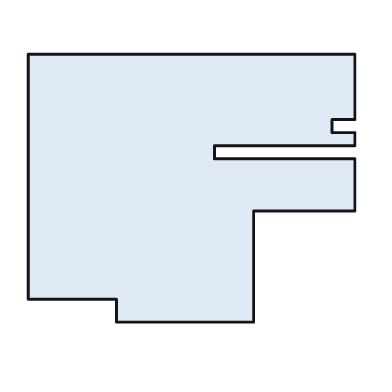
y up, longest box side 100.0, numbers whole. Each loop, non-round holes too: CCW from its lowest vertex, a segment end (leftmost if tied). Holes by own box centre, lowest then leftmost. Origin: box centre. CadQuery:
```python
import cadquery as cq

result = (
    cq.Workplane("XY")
    .moveTo(-23.0, -41.0)
    .lineTo(19.0, -41.0)
    .lineTo(19.0, -7.0)
    .lineTo(50.0, -7.0)
    .lineTo(50.0, 9.0)
    .lineTo(7.0, 9.0)
    .lineTo(7.0, 13.0)
    .lineTo(50.0, 13.0)
    .lineTo(50.0, 17.0)
    .lineTo(43.0, 17.0)
    .lineTo(43.0, 21.0)
    .lineTo(50.0, 21.0)
    .lineTo(50.0, 41.0)
    .lineTo(-50.0, 41.0)
    .lineTo(-50.0, -34.0)
    .lineTo(-23.0, -34.0)
    .close()
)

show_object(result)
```